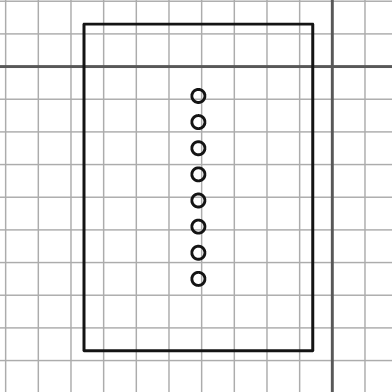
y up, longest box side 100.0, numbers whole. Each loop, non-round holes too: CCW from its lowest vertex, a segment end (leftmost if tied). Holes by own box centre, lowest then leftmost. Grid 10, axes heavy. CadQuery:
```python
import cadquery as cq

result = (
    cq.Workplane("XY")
    .moveTo(-76.0, -87.0)
    .lineTo(-6.0, -87.0)
    .lineTo(-6.0, 13.0)
    .lineTo(-76.0, 13.0)
    .close()
    .moveTo(-41.0, -65.0)
    .circle(2.0)
    .moveTo(-41.0, -57.0)
    .circle(2.0)
    .moveTo(-41.0, -49.0)
    .circle(2.0)
    .moveTo(-41.0, -41.0)
    .circle(2.0)
    .moveTo(-41.0, -33.0)
    .circle(2.0)
    .moveTo(-41.0, -25.0)
    .circle(2.0)
    .moveTo(-41.0, -17.0)
    .circle(2.0)
    .moveTo(-41.0, -9.0)
    .circle(2.0)
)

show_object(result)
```